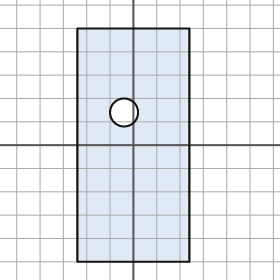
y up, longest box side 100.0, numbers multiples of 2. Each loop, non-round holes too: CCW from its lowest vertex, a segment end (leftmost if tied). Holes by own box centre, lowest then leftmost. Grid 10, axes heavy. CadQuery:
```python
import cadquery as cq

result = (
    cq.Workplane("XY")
    .moveTo(-24.0, -50.0)
    .lineTo(24.0, -50.0)
    .lineTo(24.0, 50.0)
    .lineTo(-24.0, 50.0)
    .close()
    .moveTo(-4.0, 14.0)
    .circle(6.0)
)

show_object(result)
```